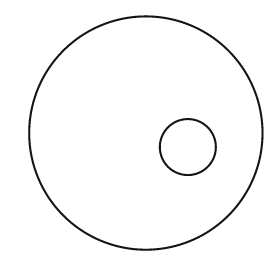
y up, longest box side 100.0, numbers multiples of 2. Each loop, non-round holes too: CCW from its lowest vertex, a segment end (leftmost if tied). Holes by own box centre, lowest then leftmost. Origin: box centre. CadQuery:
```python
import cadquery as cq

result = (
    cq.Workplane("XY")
    .moveTo(0.0, 0.0)
    .circle(50.0)
    .moveTo(18.0, -6.0)
    .circle(12.0)
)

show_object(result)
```